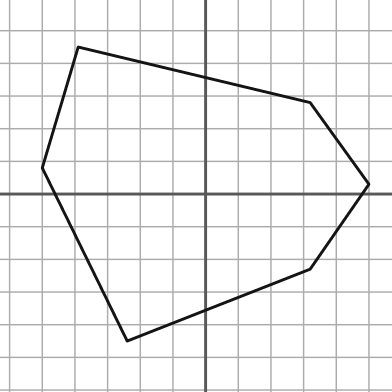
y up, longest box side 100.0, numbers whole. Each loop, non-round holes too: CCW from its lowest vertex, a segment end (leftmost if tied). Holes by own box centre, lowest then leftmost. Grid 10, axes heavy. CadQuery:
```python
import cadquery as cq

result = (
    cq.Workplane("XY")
    .moveTo(-24.0, -45.0)
    .lineTo(32.0, -23.0)
    .lineTo(50.0, 3.0)
    .lineTo(32.0, 28.0)
    .lineTo(-39.0, 45.0)
    .lineTo(-50.0, 8.0)
    .close()
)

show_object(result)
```